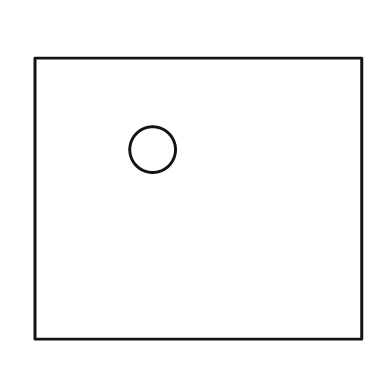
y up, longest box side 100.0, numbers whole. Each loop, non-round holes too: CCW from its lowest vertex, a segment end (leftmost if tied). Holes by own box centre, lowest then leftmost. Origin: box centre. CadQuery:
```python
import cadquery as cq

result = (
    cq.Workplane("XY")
    .moveTo(-50.0, -43.0)
    .lineTo(50.0, -43.0)
    .lineTo(50.0, 43.0)
    .lineTo(-50.0, 43.0)
    .close()
    .moveTo(-14.0, 15.0)
    .circle(7.0)
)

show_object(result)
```